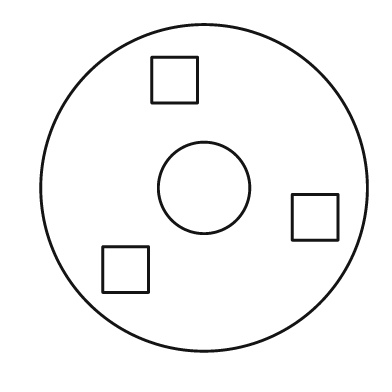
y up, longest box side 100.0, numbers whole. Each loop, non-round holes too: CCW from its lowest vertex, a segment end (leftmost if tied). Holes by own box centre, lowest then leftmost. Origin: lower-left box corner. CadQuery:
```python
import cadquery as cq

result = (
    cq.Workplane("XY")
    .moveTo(50.0, 50.0)
    .circle(50.0)
    .moveTo(19.0, 18.0)
    .lineTo(33.0, 18.0)
    .lineTo(33.0, 32.0)
    .lineTo(19.0, 32.0)
    .close()
    .moveTo(77.0, 34.0)
    .lineTo(91.0, 34.0)
    .lineTo(91.0, 48.0)
    .lineTo(77.0, 48.0)
    .close()
    .moveTo(50.0, 50.0)
    .circle(14.0)
    .moveTo(34.0, 76.0)
    .lineTo(48.0, 76.0)
    .lineTo(48.0, 90.0)
    .lineTo(34.0, 90.0)
    .close()
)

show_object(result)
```